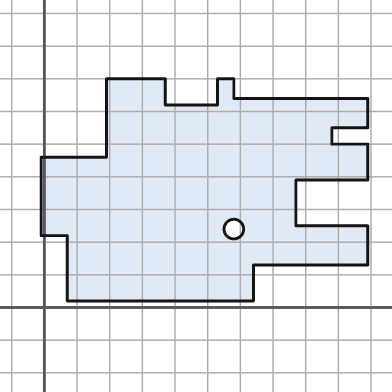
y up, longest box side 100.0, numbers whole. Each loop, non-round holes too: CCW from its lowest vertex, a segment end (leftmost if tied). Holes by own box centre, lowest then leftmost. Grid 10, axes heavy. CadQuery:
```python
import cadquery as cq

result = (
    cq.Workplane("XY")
    .moveTo(7.0, 2.0)
    .lineTo(64.0, 2.0)
    .lineTo(64.0, 13.0)
    .lineTo(99.0, 13.0)
    .lineTo(99.0, 25.0)
    .lineTo(77.0, 25.0)
    .lineTo(77.0, 39.0)
    .lineTo(99.0, 39.0)
    .lineTo(99.0, 50.0)
    .lineTo(88.0, 50.0)
    .lineTo(88.0, 55.0)
    .lineTo(99.0, 55.0)
    .lineTo(99.0, 64.0)
    .lineTo(58.0, 64.0)
    .lineTo(58.0, 70.0)
    .lineTo(53.0, 70.0)
    .lineTo(53.0, 62.0)
    .lineTo(37.0, 62.0)
    .lineTo(37.0, 70.0)
    .lineTo(19.0, 70.0)
    .lineTo(19.0, 46.0)
    .lineTo(-1.0, 46.0)
    .lineTo(-1.0, 22.0)
    .lineTo(7.0, 22.0)
    .close()
    .moveTo(58.0, 24.0)
    .circle(3.0)
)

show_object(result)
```